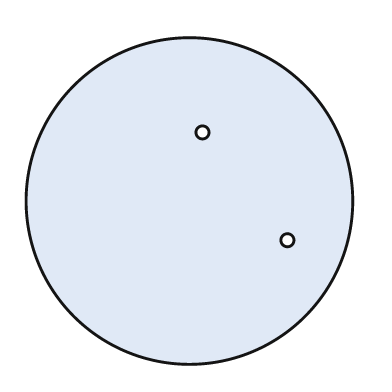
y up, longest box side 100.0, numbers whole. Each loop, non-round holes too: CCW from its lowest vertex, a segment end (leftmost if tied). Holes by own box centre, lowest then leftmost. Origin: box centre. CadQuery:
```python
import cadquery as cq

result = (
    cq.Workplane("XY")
    .moveTo(0.0, 0.0)
    .circle(50.0)
    .moveTo(30.0, -12.0)
    .circle(2.0)
    .moveTo(4.0, 21.0)
    .circle(2.0)
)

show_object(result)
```